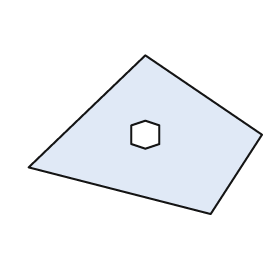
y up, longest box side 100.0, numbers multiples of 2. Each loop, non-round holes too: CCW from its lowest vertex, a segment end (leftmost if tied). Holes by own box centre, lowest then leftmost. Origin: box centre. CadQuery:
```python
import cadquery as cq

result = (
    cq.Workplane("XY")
    .moveTo(28.0, -34.0)
    .lineTo(50.0, 0.0)
    .lineTo(0.0, 34.0)
    .lineTo(-50.0, -14.0)
    .close()
    .moveTo(0.0, -6.0)
    .lineTo(6.0, -4.0)
    .lineTo(6.0, 4.0)
    .lineTo(0.0, 6.0)
    .lineTo(-6.0, 4.0)
    .lineTo(-6.0, -4.0)
    .close()
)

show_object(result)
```